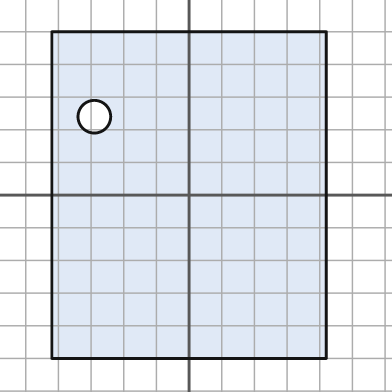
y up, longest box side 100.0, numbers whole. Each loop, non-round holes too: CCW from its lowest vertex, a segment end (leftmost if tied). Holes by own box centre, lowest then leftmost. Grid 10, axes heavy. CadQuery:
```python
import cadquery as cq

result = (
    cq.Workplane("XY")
    .moveTo(-42.0, -50.0)
    .lineTo(42.0, -50.0)
    .lineTo(42.0, 50.0)
    .lineTo(-42.0, 50.0)
    .close()
    .moveTo(-29.0, 24.0)
    .circle(5.0)
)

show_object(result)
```